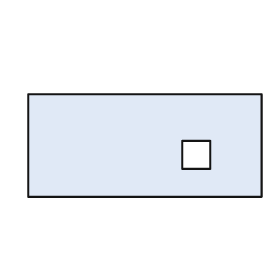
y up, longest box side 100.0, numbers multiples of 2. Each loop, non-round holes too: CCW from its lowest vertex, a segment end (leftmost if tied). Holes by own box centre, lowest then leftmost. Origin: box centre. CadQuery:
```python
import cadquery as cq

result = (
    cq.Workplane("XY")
    .moveTo(-50.0, -22.0)
    .lineTo(50.0, -22.0)
    .lineTo(50.0, 22.0)
    .lineTo(-50.0, 22.0)
    .close()
    .moveTo(16.0, -10.0)
    .lineTo(28.0, -10.0)
    .lineTo(28.0, 2.0)
    .lineTo(16.0, 2.0)
    .close()
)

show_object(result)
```